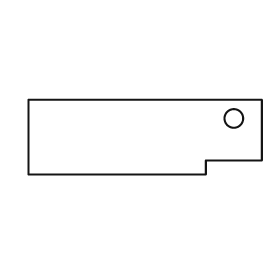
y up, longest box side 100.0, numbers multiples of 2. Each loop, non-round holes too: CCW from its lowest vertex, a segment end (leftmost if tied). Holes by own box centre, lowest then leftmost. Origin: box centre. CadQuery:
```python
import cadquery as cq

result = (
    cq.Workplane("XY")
    .moveTo(-50.0, -16.0)
    .lineTo(26.0, -16.0)
    .lineTo(26.0, -10.0)
    .lineTo(50.0, -10.0)
    .lineTo(50.0, 16.0)
    .lineTo(-50.0, 16.0)
    .close()
    .moveTo(38.0, 8.0)
    .circle(4.0)
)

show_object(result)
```